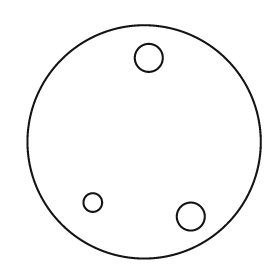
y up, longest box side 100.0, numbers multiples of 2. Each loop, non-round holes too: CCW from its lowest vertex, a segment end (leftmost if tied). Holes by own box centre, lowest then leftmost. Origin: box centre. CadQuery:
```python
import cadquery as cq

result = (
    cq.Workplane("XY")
    .moveTo(0.0, 0.0)
    .circle(50.0)
    .moveTo(20.0, -32.0)
    .circle(6.0)
    .moveTo(-22.0, -26.0)
    .circle(4.0)
    .moveTo(2.0, 36.0)
    .circle(6.0)
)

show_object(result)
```